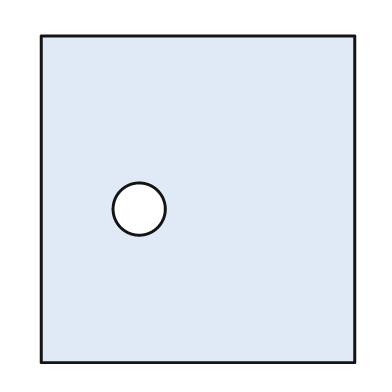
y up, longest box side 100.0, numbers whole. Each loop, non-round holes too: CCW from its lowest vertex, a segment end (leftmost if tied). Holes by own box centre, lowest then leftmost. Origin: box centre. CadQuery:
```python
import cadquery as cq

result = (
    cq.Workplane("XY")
    .moveTo(-48.0, -50.0)
    .lineTo(48.0, -50.0)
    .lineTo(48.0, 50.0)
    .lineTo(-48.0, 50.0)
    .close()
    .moveTo(-18.0, -3.0)
    .circle(8.0)
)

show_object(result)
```